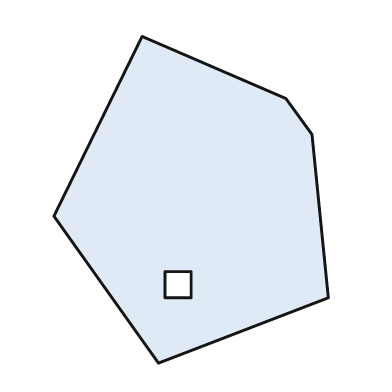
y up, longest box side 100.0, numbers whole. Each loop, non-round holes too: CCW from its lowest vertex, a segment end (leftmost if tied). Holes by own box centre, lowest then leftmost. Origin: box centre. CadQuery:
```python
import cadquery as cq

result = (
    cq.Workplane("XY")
    .moveTo(-10.0, -50.0)
    .lineTo(42.0, -30.0)
    .lineTo(37.0, 20.0)
    .lineTo(29.0, 31.0)
    .lineTo(-15.0, 50.0)
    .lineTo(-42.0, -5.0)
    .close()
    .moveTo(-8.0, -30.0)
    .lineTo(0.0, -30.0)
    .lineTo(0.0, -22.0)
    .lineTo(-8.0, -22.0)
    .close()
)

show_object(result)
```